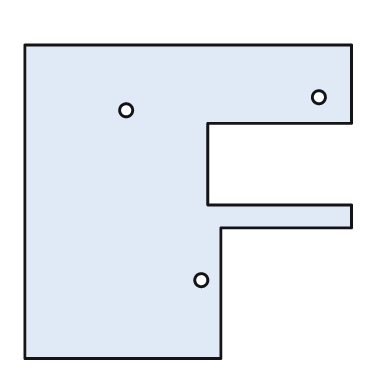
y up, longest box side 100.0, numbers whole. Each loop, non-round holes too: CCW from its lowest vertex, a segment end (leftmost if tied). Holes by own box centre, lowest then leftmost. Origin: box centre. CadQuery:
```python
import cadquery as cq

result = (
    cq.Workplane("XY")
    .moveTo(-50.0, -48.0)
    .lineTo(10.0, -48.0)
    .lineTo(10.0, -8.0)
    .lineTo(50.0, -8.0)
    .lineTo(50.0, -1.0)
    .lineTo(6.0, -1.0)
    .lineTo(6.0, 24.0)
    .lineTo(50.0, 24.0)
    .lineTo(50.0, 48.0)
    .lineTo(-50.0, 48.0)
    .close()
    .moveTo(4.0, -24.0)
    .circle(2.0)
    .moveTo(-19.0, 28.0)
    .circle(2.0)
    .moveTo(40.0, 32.0)
    .circle(2.0)
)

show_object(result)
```